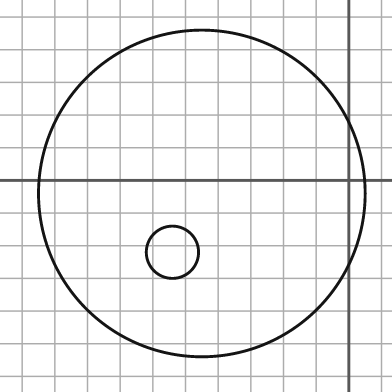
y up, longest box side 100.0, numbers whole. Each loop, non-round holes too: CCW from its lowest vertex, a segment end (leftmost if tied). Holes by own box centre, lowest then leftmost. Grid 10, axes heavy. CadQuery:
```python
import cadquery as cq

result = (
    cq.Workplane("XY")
    .moveTo(-45.0, -4.0)
    .circle(50.0)
    .moveTo(-54.0, -22.0)
    .circle(8.0)
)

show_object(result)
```